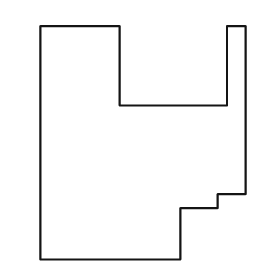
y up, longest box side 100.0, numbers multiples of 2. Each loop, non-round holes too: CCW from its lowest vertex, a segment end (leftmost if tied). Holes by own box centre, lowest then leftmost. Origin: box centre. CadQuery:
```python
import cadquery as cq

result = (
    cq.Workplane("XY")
    .moveTo(-44.0, -50.0)
    .lineTo(16.0, -50.0)
    .lineTo(16.0, -28.0)
    .lineTo(32.0, -28.0)
    .lineTo(32.0, -22.0)
    .lineTo(44.0, -22.0)
    .lineTo(44.0, 50.0)
    .lineTo(36.0, 50.0)
    .lineTo(36.0, 16.0)
    .lineTo(-10.0, 16.0)
    .lineTo(-10.0, 50.0)
    .lineTo(-44.0, 50.0)
    .close()
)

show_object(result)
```